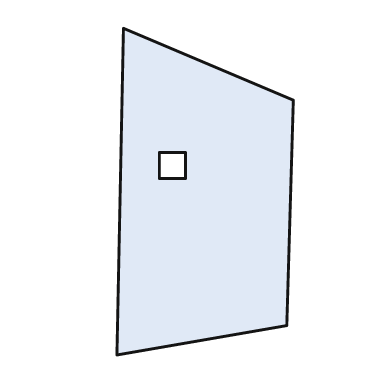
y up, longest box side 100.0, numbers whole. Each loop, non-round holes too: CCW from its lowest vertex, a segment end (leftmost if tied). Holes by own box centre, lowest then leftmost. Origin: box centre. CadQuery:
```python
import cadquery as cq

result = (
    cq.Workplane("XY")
    .moveTo(-27.0, -50.0)
    .lineTo(25.0, -41.0)
    .lineTo(27.0, 28.0)
    .lineTo(-25.0, 50.0)
    .close()
    .moveTo(-14.0, 4.0)
    .lineTo(-6.0, 4.0)
    .lineTo(-6.0, 12.0)
    .lineTo(-14.0, 12.0)
    .close()
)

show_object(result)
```